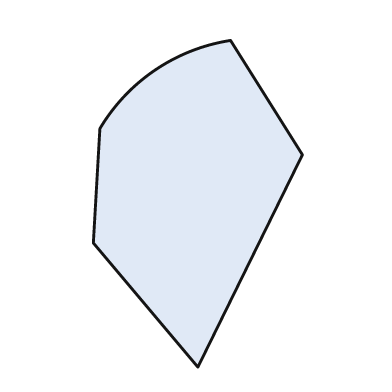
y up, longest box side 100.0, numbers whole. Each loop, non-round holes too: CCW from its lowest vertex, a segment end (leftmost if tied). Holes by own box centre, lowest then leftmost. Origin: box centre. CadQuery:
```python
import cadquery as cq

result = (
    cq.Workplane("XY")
    .moveTo(0.0, -50.0)
    .lineTo(32.0, 15.0)
    .lineTo(10.0, 50.0)
    .threePointArc((-13.0, 41.0), (-30.0, 23.0))
    .lineTo(-32.0, -12.0)
    .close()
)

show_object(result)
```